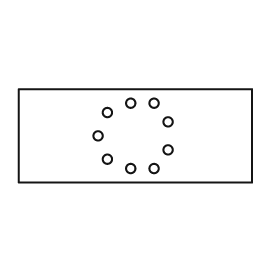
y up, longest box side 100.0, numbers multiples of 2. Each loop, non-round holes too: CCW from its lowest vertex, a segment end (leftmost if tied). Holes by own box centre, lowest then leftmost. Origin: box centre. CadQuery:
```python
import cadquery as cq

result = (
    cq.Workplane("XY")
    .moveTo(-50.0, -20.0)
    .lineTo(50.0, -20.0)
    .lineTo(50.0, 20.0)
    .lineTo(-50.0, 20.0)
    .close()
    .moveTo(-2.0, -14.0)
    .circle(2.0)
    .moveTo(8.0, -14.0)
    .circle(2.0)
    .moveTo(-12.0, -10.0)
    .circle(2.0)
    .moveTo(14.0, -6.0)
    .circle(2.0)
    .moveTo(-16.0, 0.0)
    .circle(2.0)
    .moveTo(14.0, 6.0)
    .circle(2.0)
    .moveTo(-12.0, 10.0)
    .circle(2.0)
    .moveTo(-2.0, 14.0)
    .circle(2.0)
    .moveTo(8.0, 14.0)
    .circle(2.0)
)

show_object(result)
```